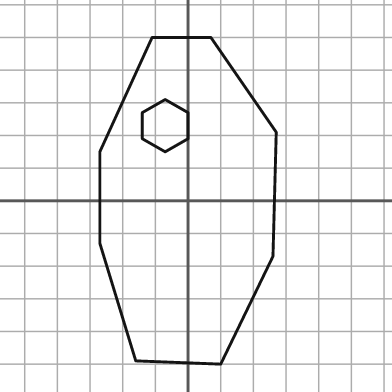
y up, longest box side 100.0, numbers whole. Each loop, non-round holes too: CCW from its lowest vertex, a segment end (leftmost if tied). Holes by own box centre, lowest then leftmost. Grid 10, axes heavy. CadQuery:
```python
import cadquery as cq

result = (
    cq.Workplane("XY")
    .moveTo(10.0, -50.0)
    .lineTo(26.0, -17.0)
    .lineTo(27.0, 21.0)
    .lineTo(7.0, 50.0)
    .lineTo(-11.0, 50.0)
    .lineTo(-27.0, 15.0)
    .lineTo(-27.0, -13.0)
    .lineTo(-16.0, -49.0)
    .close()
    .moveTo(-7.0, 15.0)
    .lineTo(0.0, 19.0)
    .lineTo(0.0, 27.0)
    .lineTo(-7.0, 31.0)
    .lineTo(-14.0, 27.0)
    .lineTo(-14.0, 19.0)
    .close()
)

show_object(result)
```